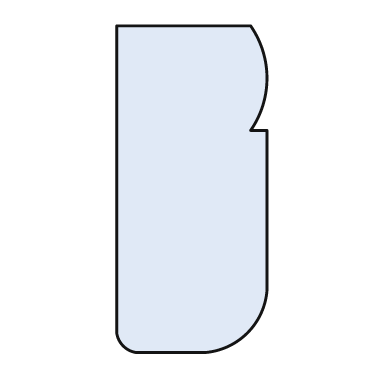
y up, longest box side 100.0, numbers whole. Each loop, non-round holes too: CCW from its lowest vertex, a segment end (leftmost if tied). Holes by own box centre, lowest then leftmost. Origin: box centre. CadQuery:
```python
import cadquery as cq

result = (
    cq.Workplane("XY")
    .moveTo(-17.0, -50.0)
    .lineTo(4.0, -50.0)
    .threePointArc((17.0, -44.0), (23.0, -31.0))
    .lineTo(23.0, 18.0)
    .lineTo(18.0, 18.0)
    .threePointArc((23.0, 34.0), (18.0, 50.0))
    .lineTo(-23.0, 50.0)
    .lineTo(-23.0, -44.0)
    .threePointArc((-21.0, -48.0), (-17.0, -50.0))
    .close()
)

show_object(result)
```